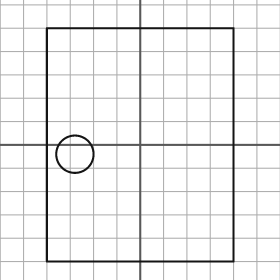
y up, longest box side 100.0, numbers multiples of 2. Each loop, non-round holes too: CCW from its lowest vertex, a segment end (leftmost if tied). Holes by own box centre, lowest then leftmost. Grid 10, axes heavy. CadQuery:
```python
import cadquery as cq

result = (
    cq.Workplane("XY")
    .moveTo(-40.0, -50.0)
    .lineTo(40.0, -50.0)
    .lineTo(40.0, 50.0)
    .lineTo(-40.0, 50.0)
    .close()
    .moveTo(-28.0, -4.0)
    .circle(8.0)
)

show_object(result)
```